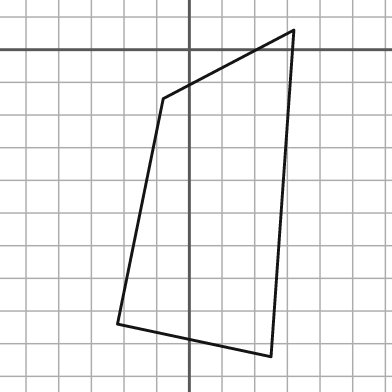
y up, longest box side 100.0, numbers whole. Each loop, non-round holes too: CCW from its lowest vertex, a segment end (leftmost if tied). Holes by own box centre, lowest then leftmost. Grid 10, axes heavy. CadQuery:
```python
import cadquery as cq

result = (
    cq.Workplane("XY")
    .moveTo(25.0, -94.0)
    .lineTo(32.0, 6.0)
    .lineTo(-8.0, -15.0)
    .lineTo(-22.0, -84.0)
    .close()
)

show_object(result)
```